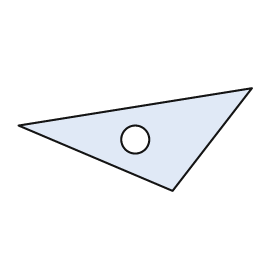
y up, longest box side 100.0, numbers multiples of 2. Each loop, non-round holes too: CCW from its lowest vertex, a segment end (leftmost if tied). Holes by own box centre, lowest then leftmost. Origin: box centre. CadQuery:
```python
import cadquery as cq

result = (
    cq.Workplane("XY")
    .moveTo(16.0, -22.0)
    .lineTo(50.0, 22.0)
    .lineTo(-50.0, 6.0)
    .close()
    .moveTo(0.0, 0.0)
    .circle(6.0)
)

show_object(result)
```